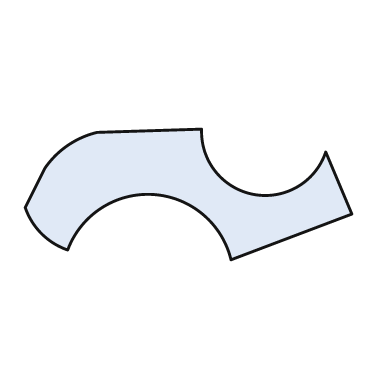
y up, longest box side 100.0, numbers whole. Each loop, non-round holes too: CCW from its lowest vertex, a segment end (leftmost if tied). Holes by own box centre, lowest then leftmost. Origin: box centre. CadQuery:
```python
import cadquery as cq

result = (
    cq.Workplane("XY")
    .moveTo(13.0, -20.0)
    .lineTo(50.0, -6.0)
    .lineTo(42.0, 13.0)
    .threePointArc((20.0, 0.0), (4.0, 20.0))
    .lineTo(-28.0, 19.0)
    .threePointArc((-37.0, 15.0), (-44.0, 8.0))
    .lineTo(-50.0, -4.0)
    .threePointArc((-45.0, -12.0), (-37.0, -17.0))
    .threePointArc((-11.0, 0.0), (13.0, -20.0))
    .close()
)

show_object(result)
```